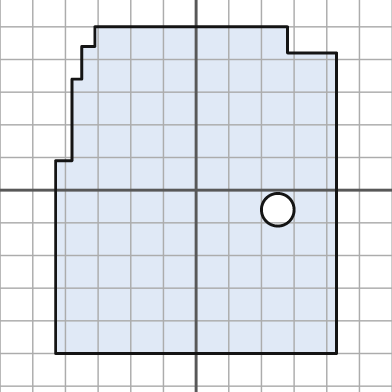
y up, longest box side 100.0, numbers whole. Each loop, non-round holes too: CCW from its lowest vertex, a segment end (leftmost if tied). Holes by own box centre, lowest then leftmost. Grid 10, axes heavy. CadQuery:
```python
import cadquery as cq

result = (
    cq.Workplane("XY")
    .moveTo(-43.0, -50.0)
    .lineTo(43.0, -50.0)
    .lineTo(43.0, 42.0)
    .lineTo(28.0, 42.0)
    .lineTo(28.0, 50.0)
    .lineTo(-31.0, 50.0)
    .lineTo(-31.0, 44.0)
    .lineTo(-35.0, 44.0)
    .lineTo(-35.0, 34.0)
    .lineTo(-38.0, 34.0)
    .lineTo(-38.0, 9.0)
    .lineTo(-43.0, 9.0)
    .close()
    .moveTo(25.0, -6.0)
    .circle(5.0)
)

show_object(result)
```